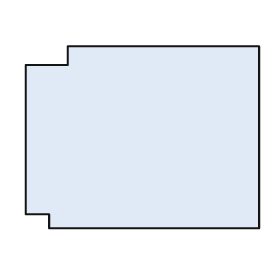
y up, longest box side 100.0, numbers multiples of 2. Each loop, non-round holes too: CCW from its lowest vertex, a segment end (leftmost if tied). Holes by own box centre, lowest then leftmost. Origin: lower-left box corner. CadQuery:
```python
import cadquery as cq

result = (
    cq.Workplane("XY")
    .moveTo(10.0, 0.0)
    .lineTo(100.0, 0.0)
    .lineTo(100.0, 78.0)
    .lineTo(18.0, 78.0)
    .lineTo(18.0, 70.0)
    .lineTo(0.0, 70.0)
    .lineTo(0.0, 6.0)
    .lineTo(10.0, 6.0)
    .close()
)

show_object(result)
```